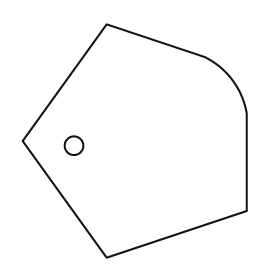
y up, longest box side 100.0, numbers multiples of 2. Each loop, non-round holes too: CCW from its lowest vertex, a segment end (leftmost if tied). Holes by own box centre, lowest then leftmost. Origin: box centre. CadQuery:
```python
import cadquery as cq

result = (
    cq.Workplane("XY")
    .moveTo(-12.0, -50.0)
    .lineTo(48.0, -30.0)
    .lineTo(48.0, 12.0)
    .threePointArc((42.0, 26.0), (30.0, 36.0))
    .lineTo(-12.0, 50.0)
    .lineTo(-48.0, 0.0)
    .close()
    .moveTo(-26.0, -2.0)
    .circle(4.0)
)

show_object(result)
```